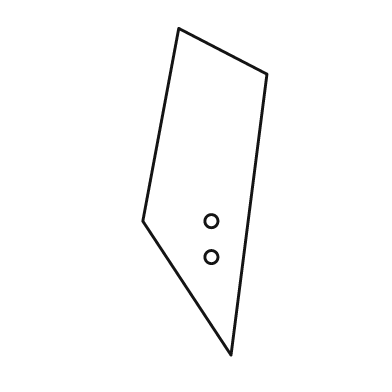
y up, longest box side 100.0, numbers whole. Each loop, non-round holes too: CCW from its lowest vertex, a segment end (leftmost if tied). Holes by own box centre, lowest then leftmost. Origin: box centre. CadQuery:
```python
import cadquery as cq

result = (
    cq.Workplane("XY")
    .moveTo(8.0, -50.0)
    .lineTo(19.0, 36.0)
    .lineTo(-8.0, 50.0)
    .lineTo(-19.0, -9.0)
    .close()
    .moveTo(2.0, -20.0)
    .circle(2.0)
    .moveTo(2.0, -9.0)
    .circle(2.0)
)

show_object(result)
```